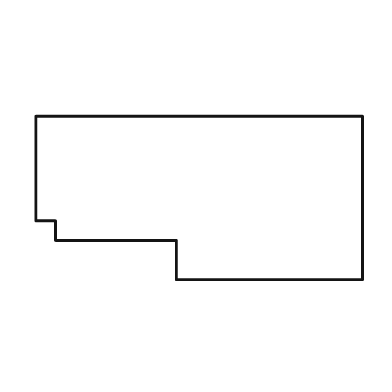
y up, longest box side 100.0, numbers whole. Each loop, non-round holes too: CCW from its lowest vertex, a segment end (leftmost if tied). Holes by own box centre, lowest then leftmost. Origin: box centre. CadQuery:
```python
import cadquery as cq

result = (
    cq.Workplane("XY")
    .moveTo(-7.0, -25.0)
    .lineTo(50.0, -25.0)
    .lineTo(50.0, 25.0)
    .lineTo(-50.0, 25.0)
    .lineTo(-50.0, -7.0)
    .lineTo(-44.0, -7.0)
    .lineTo(-44.0, -13.0)
    .lineTo(-7.0, -13.0)
    .close()
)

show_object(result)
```